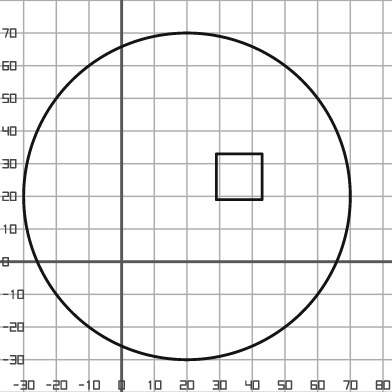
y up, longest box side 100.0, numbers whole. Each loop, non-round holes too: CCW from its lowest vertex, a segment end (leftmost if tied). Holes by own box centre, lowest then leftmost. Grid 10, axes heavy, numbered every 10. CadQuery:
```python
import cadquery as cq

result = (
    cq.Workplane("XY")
    .moveTo(20.0, 20.0)
    .circle(50.0)
    .moveTo(29.0, 19.0)
    .lineTo(43.0, 19.0)
    .lineTo(43.0, 33.0)
    .lineTo(29.0, 33.0)
    .close()
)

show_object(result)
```